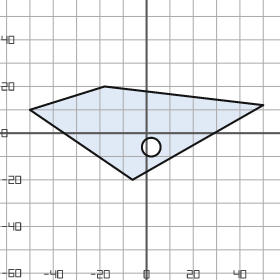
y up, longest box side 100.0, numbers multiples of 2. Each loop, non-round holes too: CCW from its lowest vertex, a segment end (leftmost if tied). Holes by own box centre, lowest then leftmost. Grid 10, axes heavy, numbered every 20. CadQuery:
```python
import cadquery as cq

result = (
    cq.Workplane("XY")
    .moveTo(-6.0, -20.0)
    .lineTo(50.0, 12.0)
    .lineTo(-18.0, 20.0)
    .lineTo(-50.0, 10.0)
    .close()
    .moveTo(2.0, -6.0)
    .circle(4.0)
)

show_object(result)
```